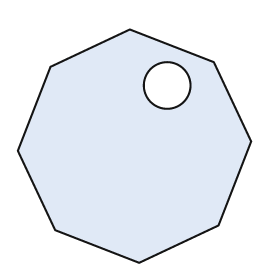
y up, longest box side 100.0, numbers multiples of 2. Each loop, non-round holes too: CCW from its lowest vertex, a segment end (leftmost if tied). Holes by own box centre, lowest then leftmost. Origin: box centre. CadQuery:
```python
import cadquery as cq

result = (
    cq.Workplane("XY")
    .moveTo(2.0, -50.0)
    .lineTo(36.0, -34.0)
    .lineTo(50.0, 2.0)
    .lineTo(34.0, 36.0)
    .lineTo(-2.0, 50.0)
    .lineTo(-36.0, 34.0)
    .lineTo(-50.0, -2.0)
    .lineTo(-34.0, -36.0)
    .close()
    .moveTo(14.0, 26.0)
    .circle(10.0)
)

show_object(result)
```